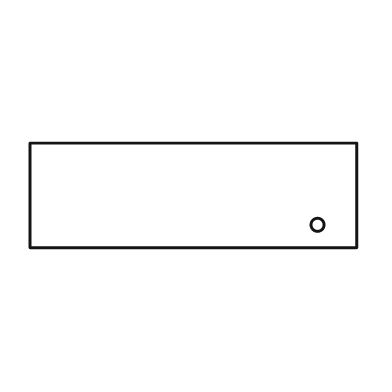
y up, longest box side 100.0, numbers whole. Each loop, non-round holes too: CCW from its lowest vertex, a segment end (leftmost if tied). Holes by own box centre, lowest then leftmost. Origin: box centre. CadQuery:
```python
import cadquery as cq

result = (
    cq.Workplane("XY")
    .moveTo(-50.0, -16.0)
    .lineTo(50.0, -16.0)
    .lineTo(50.0, 16.0)
    .lineTo(-50.0, 16.0)
    .close()
    .moveTo(38.0, -9.0)
    .circle(2.0)
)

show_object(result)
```